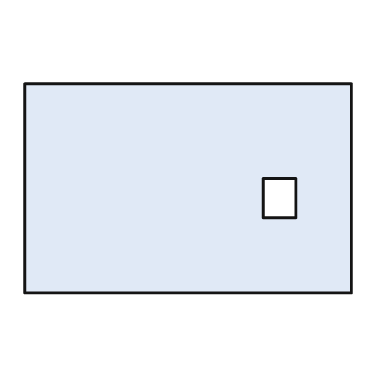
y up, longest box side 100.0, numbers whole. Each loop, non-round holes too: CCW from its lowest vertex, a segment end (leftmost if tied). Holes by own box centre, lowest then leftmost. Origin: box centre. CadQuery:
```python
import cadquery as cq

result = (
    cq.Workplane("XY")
    .moveTo(-50.0, -32.0)
    .lineTo(50.0, -32.0)
    .lineTo(50.0, 32.0)
    .lineTo(-50.0, 32.0)
    .close()
    .moveTo(23.0, -9.0)
    .lineTo(33.0, -9.0)
    .lineTo(33.0, 3.0)
    .lineTo(23.0, 3.0)
    .close()
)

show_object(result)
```